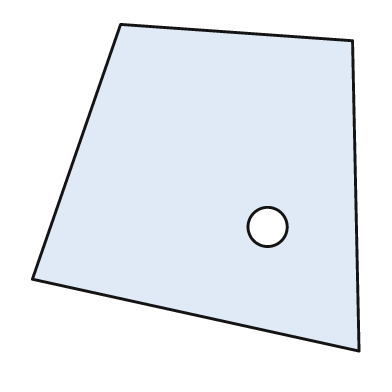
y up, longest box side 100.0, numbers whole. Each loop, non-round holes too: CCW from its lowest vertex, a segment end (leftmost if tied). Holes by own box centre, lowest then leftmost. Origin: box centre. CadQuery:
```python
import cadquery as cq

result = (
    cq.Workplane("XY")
    .moveTo(50.0, -50.0)
    .lineTo(48.0, 45.0)
    .lineTo(-23.0, 50.0)
    .lineTo(-50.0, -28.0)
    .close()
    .moveTo(22.0, -12.0)
    .circle(6.0)
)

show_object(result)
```